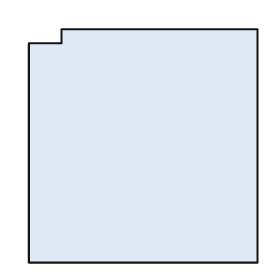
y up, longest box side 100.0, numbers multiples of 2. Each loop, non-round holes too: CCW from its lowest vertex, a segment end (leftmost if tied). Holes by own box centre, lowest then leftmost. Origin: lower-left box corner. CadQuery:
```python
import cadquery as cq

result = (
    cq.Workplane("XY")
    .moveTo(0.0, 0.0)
    .lineTo(98.0, 0.0)
    .lineTo(98.0, 100.0)
    .lineTo(14.0, 100.0)
    .lineTo(14.0, 94.0)
    .lineTo(0.0, 94.0)
    .close()
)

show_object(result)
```